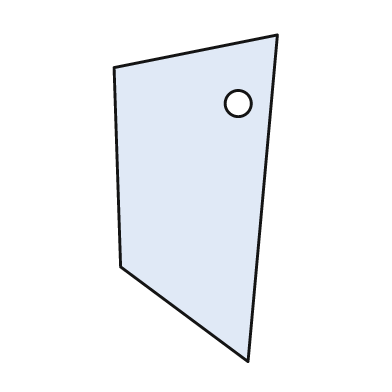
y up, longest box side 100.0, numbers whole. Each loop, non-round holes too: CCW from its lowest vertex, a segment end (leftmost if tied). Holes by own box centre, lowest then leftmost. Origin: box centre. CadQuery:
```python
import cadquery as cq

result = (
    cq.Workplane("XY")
    .moveTo(16.0, -50.0)
    .lineTo(25.0, 50.0)
    .lineTo(-25.0, 40.0)
    .lineTo(-23.0, -21.0)
    .close()
    .moveTo(13.0, 29.0)
    .circle(4.0)
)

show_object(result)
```